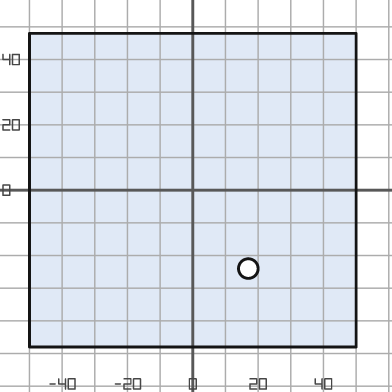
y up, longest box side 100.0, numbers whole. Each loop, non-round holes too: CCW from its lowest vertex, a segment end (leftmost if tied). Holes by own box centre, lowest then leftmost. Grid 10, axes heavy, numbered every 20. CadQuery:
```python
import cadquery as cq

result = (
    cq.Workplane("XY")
    .moveTo(-50.0, -48.0)
    .lineTo(50.0, -48.0)
    .lineTo(50.0, 48.0)
    .lineTo(-50.0, 48.0)
    .close()
    .moveTo(17.0, -24.0)
    .circle(3.0)
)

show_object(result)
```